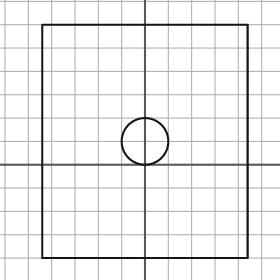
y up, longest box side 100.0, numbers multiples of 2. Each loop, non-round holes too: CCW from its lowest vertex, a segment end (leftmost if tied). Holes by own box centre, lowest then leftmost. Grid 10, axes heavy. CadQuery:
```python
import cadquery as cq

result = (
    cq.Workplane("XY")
    .moveTo(-44.0, -40.0)
    .lineTo(44.0, -40.0)
    .lineTo(44.0, 60.0)
    .lineTo(-44.0, 60.0)
    .close()
    .moveTo(0.0, 10.0)
    .circle(10.0)
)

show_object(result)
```